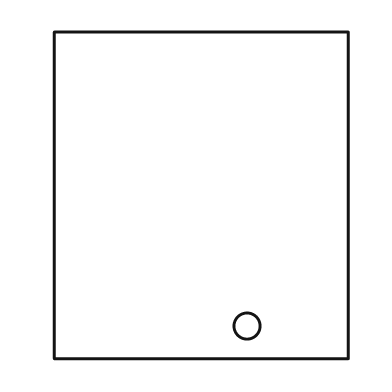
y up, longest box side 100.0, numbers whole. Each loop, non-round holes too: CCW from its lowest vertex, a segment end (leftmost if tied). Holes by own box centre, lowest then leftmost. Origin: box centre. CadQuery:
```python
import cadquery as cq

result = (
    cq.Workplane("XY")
    .moveTo(-45.0, -50.0)
    .lineTo(45.0, -50.0)
    .lineTo(45.0, 50.0)
    .lineTo(-45.0, 50.0)
    .close()
    .moveTo(14.0, -40.0)
    .circle(4.0)
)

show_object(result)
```